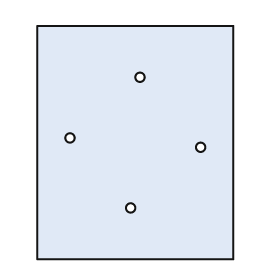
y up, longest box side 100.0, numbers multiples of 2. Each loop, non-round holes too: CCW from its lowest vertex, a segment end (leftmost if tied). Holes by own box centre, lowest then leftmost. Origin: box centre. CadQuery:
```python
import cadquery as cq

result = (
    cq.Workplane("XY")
    .moveTo(-42.0, -50.0)
    .lineTo(42.0, -50.0)
    .lineTo(42.0, 50.0)
    .lineTo(-42.0, 50.0)
    .close()
    .moveTo(-2.0, -28.0)
    .circle(2.0)
    .moveTo(28.0, -2.0)
    .circle(2.0)
    .moveTo(-28.0, 2.0)
    .circle(2.0)
    .moveTo(2.0, 28.0)
    .circle(2.0)
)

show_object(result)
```